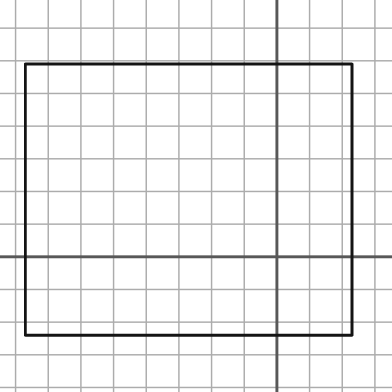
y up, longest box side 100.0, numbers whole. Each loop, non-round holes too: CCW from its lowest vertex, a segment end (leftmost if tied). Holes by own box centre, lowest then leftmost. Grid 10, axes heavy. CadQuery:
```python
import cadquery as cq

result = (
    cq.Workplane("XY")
    .moveTo(-77.0, -24.0)
    .lineTo(23.0, -24.0)
    .lineTo(23.0, 59.0)
    .lineTo(-77.0, 59.0)
    .close()
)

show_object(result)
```